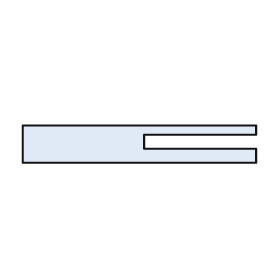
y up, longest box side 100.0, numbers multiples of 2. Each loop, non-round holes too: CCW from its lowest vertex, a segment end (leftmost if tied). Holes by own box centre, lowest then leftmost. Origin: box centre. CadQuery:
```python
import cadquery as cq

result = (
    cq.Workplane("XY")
    .moveTo(-50.0, -8.0)
    .lineTo(50.0, -8.0)
    .lineTo(50.0, -2.0)
    .lineTo(2.0, -2.0)
    .lineTo(2.0, 4.0)
    .lineTo(50.0, 4.0)
    .lineTo(50.0, 8.0)
    .lineTo(-50.0, 8.0)
    .close()
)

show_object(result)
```